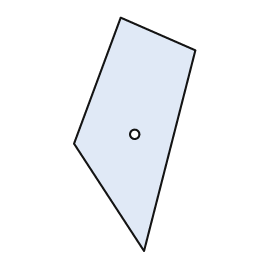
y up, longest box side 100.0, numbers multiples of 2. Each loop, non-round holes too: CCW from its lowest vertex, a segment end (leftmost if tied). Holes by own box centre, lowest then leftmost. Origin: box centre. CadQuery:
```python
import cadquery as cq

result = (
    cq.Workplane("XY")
    .moveTo(4.0, -50.0)
    .lineTo(26.0, 36.0)
    .lineTo(-6.0, 50.0)
    .lineTo(-26.0, -4.0)
    .close()
    .moveTo(0.0, 0.0)
    .circle(2.0)
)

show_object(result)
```